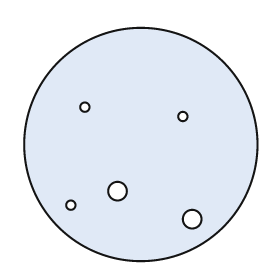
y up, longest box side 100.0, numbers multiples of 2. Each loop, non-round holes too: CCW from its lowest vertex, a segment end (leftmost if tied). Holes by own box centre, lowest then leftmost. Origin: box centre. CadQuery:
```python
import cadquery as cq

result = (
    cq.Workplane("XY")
    .moveTo(0.0, 0.0)
    .circle(50.0)
    .moveTo(22.0, -32.0)
    .circle(4.0)
    .moveTo(-30.0, -26.0)
    .circle(2.0)
    .moveTo(-10.0, -20.0)
    .circle(4.0)
    .moveTo(18.0, 12.0)
    .circle(2.0)
    .moveTo(-24.0, 16.0)
    .circle(2.0)
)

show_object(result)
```